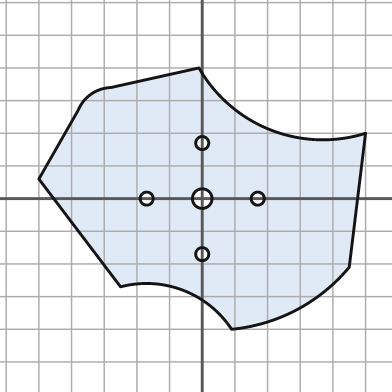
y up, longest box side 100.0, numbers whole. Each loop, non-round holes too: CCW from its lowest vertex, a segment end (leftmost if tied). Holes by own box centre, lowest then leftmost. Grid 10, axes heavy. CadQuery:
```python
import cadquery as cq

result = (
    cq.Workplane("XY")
    .moveTo(9.0, -40.0)
    .threePointArc((29.0, -34.0), (45.0, -21.0))
    .lineTo(50.0, 20.0)
    .threePointArc((21.0, 21.0), (-1.0, 40.0))
    .lineTo(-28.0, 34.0)
    .threePointArc((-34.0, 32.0), (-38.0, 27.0))
    .lineTo(-50.0, 6.0)
    .lineTo(-25.0, -27.0)
    .threePointArc((-6.0, -28.0), (9.0, -40.0))
    .close()
    .moveTo(0.0, -17.0)
    .circle(2.0)
    .moveTo(-17.0, 0.0)
    .circle(2.0)
    .moveTo(0.0, 0.0)
    .circle(3.0)
    .moveTo(17.0, 0.0)
    .circle(2.0)
    .moveTo(0.0, 17.0)
    .circle(2.0)
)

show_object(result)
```